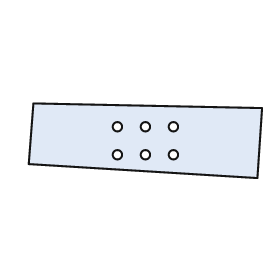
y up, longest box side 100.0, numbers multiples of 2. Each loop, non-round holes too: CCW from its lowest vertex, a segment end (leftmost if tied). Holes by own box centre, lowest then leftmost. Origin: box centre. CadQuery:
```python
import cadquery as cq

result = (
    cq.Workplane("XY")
    .moveTo(48.0, -16.0)
    .lineTo(50.0, 14.0)
    .lineTo(-48.0, 16.0)
    .lineTo(-50.0, -10.0)
    .close()
    .moveTo(-12.0, -6.0)
    .circle(2.0)
    .moveTo(0.0, -6.0)
    .circle(2.0)
    .moveTo(12.0, -6.0)
    .circle(2.0)
    .moveTo(-12.0, 6.0)
    .circle(2.0)
    .moveTo(0.0, 6.0)
    .circle(2.0)
    .moveTo(12.0, 6.0)
    .circle(2.0)
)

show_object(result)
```